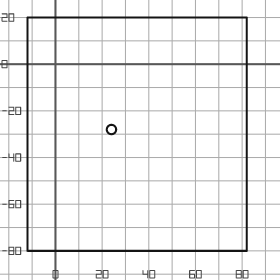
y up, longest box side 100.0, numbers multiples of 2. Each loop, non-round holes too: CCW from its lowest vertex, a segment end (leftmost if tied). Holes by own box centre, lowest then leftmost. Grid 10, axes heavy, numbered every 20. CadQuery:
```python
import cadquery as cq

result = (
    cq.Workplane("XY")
    .moveTo(-12.0, -80.0)
    .lineTo(82.0, -80.0)
    .lineTo(82.0, 20.0)
    .lineTo(-12.0, 20.0)
    .close()
    .moveTo(24.0, -28.0)
    .circle(2.0)
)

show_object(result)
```